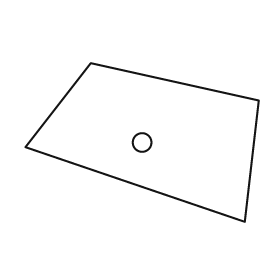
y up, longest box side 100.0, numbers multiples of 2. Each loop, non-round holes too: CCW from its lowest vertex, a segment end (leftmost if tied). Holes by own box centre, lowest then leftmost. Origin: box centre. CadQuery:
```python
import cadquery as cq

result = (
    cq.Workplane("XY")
    .moveTo(44.0, -34.0)
    .lineTo(50.0, 18.0)
    .lineTo(-22.0, 34.0)
    .lineTo(-50.0, -2.0)
    .close()
    .moveTo(0.0, 0.0)
    .circle(4.0)
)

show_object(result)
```